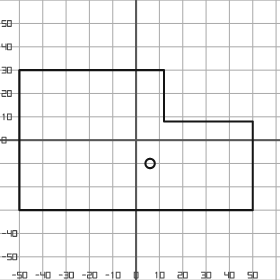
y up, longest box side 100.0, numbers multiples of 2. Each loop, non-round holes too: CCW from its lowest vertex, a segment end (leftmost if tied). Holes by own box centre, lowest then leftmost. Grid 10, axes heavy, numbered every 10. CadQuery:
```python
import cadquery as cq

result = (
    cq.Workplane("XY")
    .moveTo(-50.0, -30.0)
    .lineTo(50.0, -30.0)
    .lineTo(50.0, 8.0)
    .lineTo(12.0, 8.0)
    .lineTo(12.0, 30.0)
    .lineTo(-50.0, 30.0)
    .close()
    .moveTo(6.0, -10.0)
    .circle(2.0)
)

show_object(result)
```